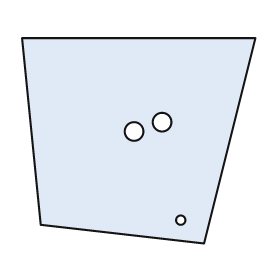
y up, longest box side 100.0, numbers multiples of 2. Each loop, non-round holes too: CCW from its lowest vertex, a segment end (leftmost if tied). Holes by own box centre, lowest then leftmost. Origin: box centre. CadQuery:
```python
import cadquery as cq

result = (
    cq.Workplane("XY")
    .moveTo(28.0, -44.0)
    .lineTo(50.0, 44.0)
    .lineTo(-50.0, 44.0)
    .lineTo(-42.0, -36.0)
    .close()
    .moveTo(18.0, -34.0)
    .circle(2.0)
    .moveTo(-2.0, 4.0)
    .circle(4.0)
    .moveTo(10.0, 8.0)
    .circle(4.0)
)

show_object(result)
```